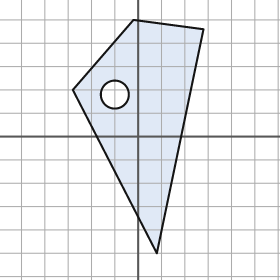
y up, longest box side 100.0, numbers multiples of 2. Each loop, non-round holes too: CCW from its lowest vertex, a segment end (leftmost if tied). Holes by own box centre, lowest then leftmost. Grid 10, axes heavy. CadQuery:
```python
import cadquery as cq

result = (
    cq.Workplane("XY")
    .moveTo(8.0, -50.0)
    .lineTo(28.0, 46.0)
    .lineTo(-2.0, 50.0)
    .lineTo(-28.0, 20.0)
    .close()
    .moveTo(-10.0, 18.0)
    .circle(6.0)
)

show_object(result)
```